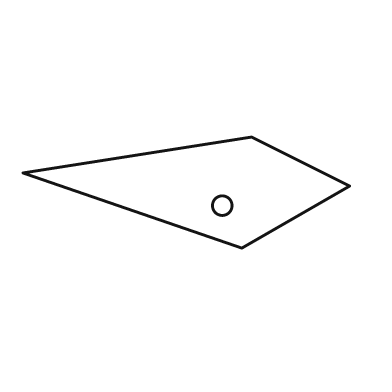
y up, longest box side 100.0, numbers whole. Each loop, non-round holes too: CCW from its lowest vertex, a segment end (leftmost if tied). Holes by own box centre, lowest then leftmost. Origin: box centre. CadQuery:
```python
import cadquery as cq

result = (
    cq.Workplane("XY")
    .moveTo(17.0, -17.0)
    .lineTo(50.0, 2.0)
    .lineTo(20.0, 17.0)
    .lineTo(-50.0, 6.0)
    .close()
    .moveTo(11.0, -4.0)
    .circle(3.0)
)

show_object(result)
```